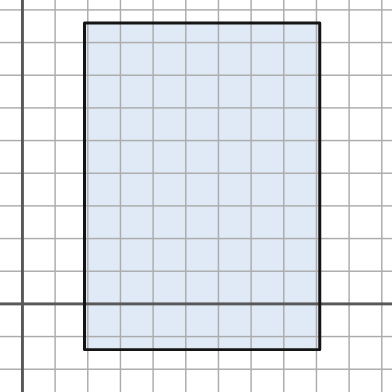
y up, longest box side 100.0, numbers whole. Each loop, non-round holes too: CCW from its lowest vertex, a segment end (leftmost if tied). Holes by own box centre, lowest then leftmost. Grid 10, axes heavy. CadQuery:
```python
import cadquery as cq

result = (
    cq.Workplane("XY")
    .moveTo(19.0, -14.0)
    .lineTo(91.0, -14.0)
    .lineTo(91.0, 86.0)
    .lineTo(19.0, 86.0)
    .close()
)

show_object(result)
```